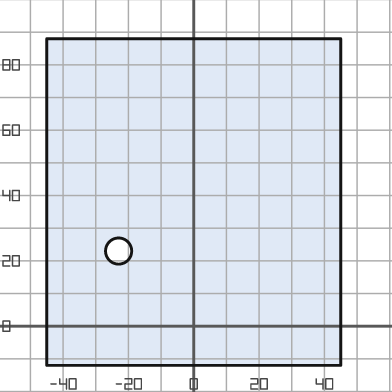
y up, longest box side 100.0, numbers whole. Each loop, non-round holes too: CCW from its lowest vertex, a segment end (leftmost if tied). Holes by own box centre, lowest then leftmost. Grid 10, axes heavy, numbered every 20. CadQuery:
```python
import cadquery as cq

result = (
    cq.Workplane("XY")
    .moveTo(-45.0, -12.0)
    .lineTo(45.0, -12.0)
    .lineTo(45.0, 88.0)
    .lineTo(-45.0, 88.0)
    .close()
    .moveTo(-23.0, 23.0)
    .circle(4.0)
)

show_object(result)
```